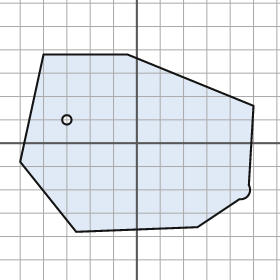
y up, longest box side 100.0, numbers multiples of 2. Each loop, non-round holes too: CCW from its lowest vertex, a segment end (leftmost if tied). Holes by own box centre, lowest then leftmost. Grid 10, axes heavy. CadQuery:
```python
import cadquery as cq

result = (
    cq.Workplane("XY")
    .moveTo(-26.0, -38.0)
    .lineTo(26.0, -36.0)
    .lineTo(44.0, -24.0)
    .threePointArc((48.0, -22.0), (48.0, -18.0))
    .lineTo(50.0, 16.0)
    .lineTo(-4.0, 38.0)
    .lineTo(-40.0, 38.0)
    .lineTo(-50.0, -8.0)
    .close()
    .moveTo(-30.0, 10.0)
    .circle(2.0)
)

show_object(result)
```